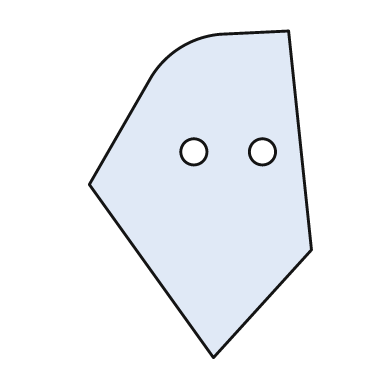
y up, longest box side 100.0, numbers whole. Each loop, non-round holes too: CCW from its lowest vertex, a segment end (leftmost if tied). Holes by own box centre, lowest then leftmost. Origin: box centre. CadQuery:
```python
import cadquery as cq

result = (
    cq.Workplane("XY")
    .moveTo(4.0, -50.0)
    .lineTo(34.0, -17.0)
    .lineTo(27.0, 50.0)
    .lineTo(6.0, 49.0)
    .threePointArc((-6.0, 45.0), (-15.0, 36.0))
    .lineTo(-34.0, 3.0)
    .close()
    .moveTo(-2.0, 13.0)
    .circle(4.0)
    .moveTo(19.0, 13.0)
    .circle(4.0)
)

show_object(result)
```